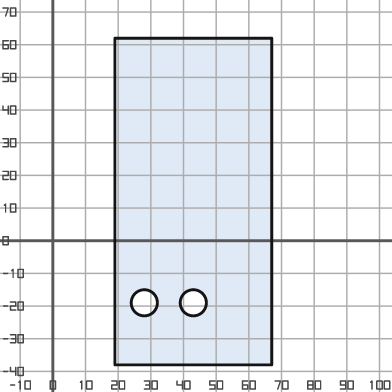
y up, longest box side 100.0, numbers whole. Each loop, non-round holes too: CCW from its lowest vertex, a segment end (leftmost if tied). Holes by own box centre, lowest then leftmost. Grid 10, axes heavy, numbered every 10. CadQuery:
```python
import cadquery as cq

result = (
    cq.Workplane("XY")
    .moveTo(19.0, -38.0)
    .lineTo(67.0, -38.0)
    .lineTo(67.0, 62.0)
    .lineTo(19.0, 62.0)
    .close()
    .moveTo(28.0, -19.0)
    .circle(4.0)
    .moveTo(43.0, -19.0)
    .circle(4.0)
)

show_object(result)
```